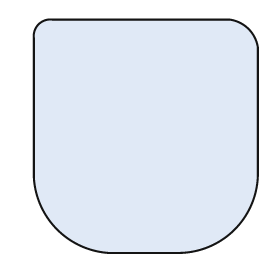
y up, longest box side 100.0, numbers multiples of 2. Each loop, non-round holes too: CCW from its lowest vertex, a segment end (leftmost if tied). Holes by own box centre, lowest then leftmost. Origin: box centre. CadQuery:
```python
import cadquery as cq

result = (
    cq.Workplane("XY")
    .moveTo(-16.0, -50.0)
    .lineTo(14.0, -50.0)
    .threePointArc((38.0, -40.0), (48.0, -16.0))
    .lineTo(48.0, 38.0)
    .threePointArc((44.0, 46.0), (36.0, 50.0))
    .lineTo(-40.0, 50.0)
    .threePointArc((-46.0, 48.0), (-48.0, 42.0))
    .lineTo(-48.0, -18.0)
    .threePointArc((-38.0, -40.0), (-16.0, -50.0))
    .close()
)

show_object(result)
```